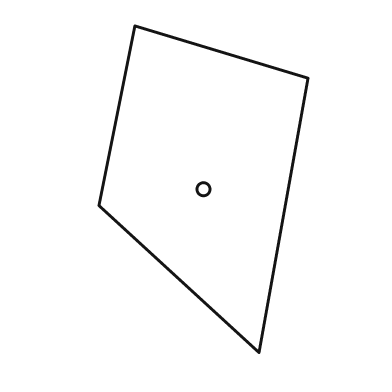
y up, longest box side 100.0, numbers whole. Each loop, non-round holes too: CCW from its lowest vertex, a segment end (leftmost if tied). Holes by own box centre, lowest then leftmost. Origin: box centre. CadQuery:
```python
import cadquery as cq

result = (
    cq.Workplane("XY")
    .moveTo(17.0, -50.0)
    .lineTo(32.0, 34.0)
    .lineTo(-21.0, 50.0)
    .lineTo(-32.0, -5.0)
    .close()
    .moveTo(0.0, 0.0)
    .circle(2.0)
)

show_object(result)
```